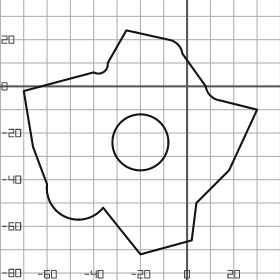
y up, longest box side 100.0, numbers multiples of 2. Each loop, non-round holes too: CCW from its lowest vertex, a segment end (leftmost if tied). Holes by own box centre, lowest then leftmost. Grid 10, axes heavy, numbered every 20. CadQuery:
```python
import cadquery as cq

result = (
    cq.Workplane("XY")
    .moveTo(-20.0, -72.0)
    .lineTo(2.0, -66.0)
    .lineTo(4.0, -50.0)
    .lineTo(18.0, -36.0)
    .lineTo(30.0, -10.0)
    .lineTo(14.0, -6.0)
    .threePointArc((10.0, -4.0), (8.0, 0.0))
    .lineTo(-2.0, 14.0)
    .threePointArc((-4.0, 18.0), (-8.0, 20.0))
    .lineTo(-26.0, 24.0)
    .lineTo(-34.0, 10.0)
    .threePointArc((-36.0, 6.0), (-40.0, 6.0))
    .lineTo(-70.0, -2.0)
    .lineTo(-66.0, -26.0)
    .lineTo(-60.0, -42.0)
    .threePointArc((-52.0, -56.0), (-36.0, -52.0))
    .close()
    .moveTo(-20.0, -24.0)
    .circle(12.0)
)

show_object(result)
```